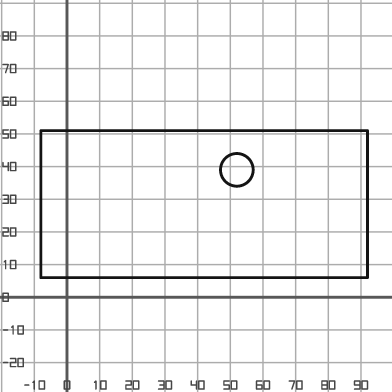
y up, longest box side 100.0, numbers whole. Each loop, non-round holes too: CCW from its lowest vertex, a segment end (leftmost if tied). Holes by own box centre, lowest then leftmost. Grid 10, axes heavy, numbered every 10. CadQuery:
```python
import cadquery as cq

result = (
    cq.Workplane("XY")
    .moveTo(-8.0, 6.0)
    .lineTo(92.0, 6.0)
    .lineTo(92.0, 51.0)
    .lineTo(-8.0, 51.0)
    .close()
    .moveTo(52.0, 39.0)
    .circle(5.0)
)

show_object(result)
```